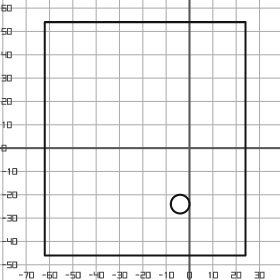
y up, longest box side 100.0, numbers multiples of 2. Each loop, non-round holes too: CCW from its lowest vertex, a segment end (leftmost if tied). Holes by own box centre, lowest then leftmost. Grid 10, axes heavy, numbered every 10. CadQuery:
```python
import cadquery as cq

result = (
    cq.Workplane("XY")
    .moveTo(-62.0, -46.0)
    .lineTo(24.0, -46.0)
    .lineTo(24.0, 54.0)
    .lineTo(-62.0, 54.0)
    .close()
    .moveTo(-4.0, -24.0)
    .circle(4.0)
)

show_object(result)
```